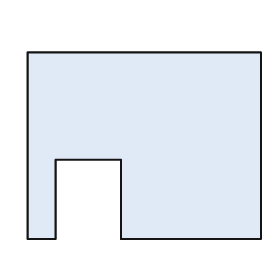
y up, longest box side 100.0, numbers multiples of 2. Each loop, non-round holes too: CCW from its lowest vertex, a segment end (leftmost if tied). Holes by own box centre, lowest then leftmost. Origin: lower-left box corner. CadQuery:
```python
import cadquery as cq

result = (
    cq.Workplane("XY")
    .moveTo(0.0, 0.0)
    .lineTo(12.0, 0.0)
    .lineTo(12.0, 34.0)
    .lineTo(40.0, 34.0)
    .lineTo(40.0, 0.0)
    .lineTo(100.0, 0.0)
    .lineTo(100.0, 80.0)
    .lineTo(0.0, 80.0)
    .close()
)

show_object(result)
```